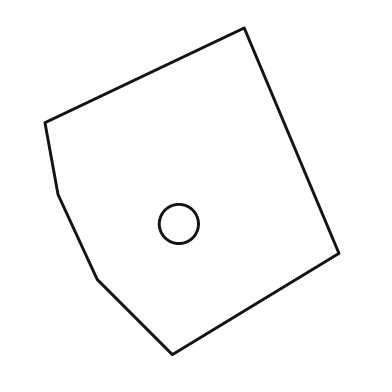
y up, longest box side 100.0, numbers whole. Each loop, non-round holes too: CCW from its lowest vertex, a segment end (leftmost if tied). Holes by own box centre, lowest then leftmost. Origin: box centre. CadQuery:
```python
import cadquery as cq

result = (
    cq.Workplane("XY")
    .moveTo(-6.0, -50.0)
    .lineTo(45.0, -19.0)
    .lineTo(16.0, 50.0)
    .lineTo(-45.0, 21.0)
    .lineTo(-41.0, -1.0)
    .lineTo(-29.0, -27.0)
    .close()
    .moveTo(-4.0, -10.0)
    .circle(6.0)
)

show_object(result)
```